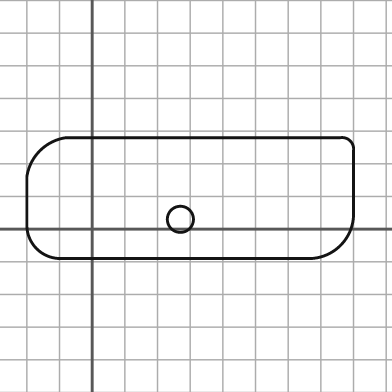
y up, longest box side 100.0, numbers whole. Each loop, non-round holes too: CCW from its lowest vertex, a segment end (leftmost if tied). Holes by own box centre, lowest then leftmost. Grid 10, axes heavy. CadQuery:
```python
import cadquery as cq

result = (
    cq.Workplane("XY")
    .moveTo(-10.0, -9.0)
    .lineTo(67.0, -9.0)
    .threePointArc((76.0, -5.0), (80.0, 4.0))
    .lineTo(80.0, 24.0)
    .threePointArc((79.0, 27.0), (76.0, 28.0))
    .lineTo(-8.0, 28.0)
    .threePointArc((-16.0, 24.0), (-20.0, 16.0))
    .lineTo(-20.0, 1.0)
    .threePointArc((-17.0, -6.0), (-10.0, -9.0))
    .close()
    .moveTo(27.0, 3.0)
    .circle(4.0)
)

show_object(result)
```